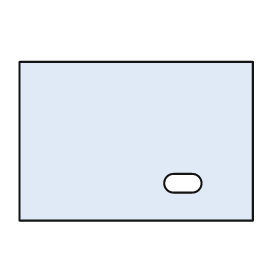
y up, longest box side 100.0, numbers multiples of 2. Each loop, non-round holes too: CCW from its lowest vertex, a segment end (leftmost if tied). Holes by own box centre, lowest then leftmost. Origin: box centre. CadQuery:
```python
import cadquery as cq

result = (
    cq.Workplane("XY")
    .moveTo(-50.0, -34.0)
    .lineTo(50.0, -34.0)
    .lineTo(50.0, 34.0)
    .lineTo(-50.0, 34.0)
    .close()
    .moveTo(16.0, -22.0)
    .lineTo(24.0, -22.0)
    .threePointArc((28.0, -18.0), (24.0, -14.0))
    .lineTo(16.0, -14.0)
    .threePointArc((12.0, -18.0), (16.0, -22.0))
    .close()
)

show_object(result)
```